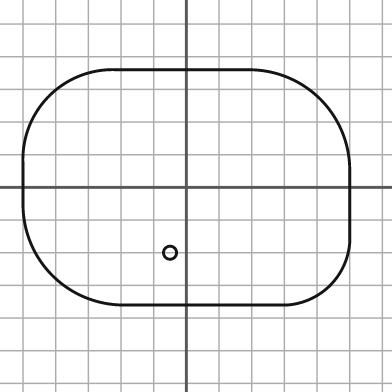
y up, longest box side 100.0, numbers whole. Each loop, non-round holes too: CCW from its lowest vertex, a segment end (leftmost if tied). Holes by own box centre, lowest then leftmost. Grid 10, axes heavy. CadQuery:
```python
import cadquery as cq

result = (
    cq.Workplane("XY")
    .moveTo(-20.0, -36.0)
    .lineTo(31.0, -36.0)
    .threePointArc((44.0, -30.0), (50.0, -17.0))
    .lineTo(50.0, 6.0)
    .threePointArc((41.0, 27.0), (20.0, 36.0))
    .lineTo(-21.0, 36.0)
    .threePointArc((-42.0, 28.0), (-50.0, 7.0))
    .lineTo(-50.0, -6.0)
    .threePointArc((-41.0, -27.0), (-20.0, -36.0))
    .close()
    .moveTo(-5.0, -20.0)
    .circle(2.0)
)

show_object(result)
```